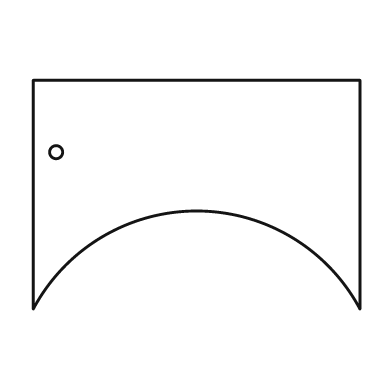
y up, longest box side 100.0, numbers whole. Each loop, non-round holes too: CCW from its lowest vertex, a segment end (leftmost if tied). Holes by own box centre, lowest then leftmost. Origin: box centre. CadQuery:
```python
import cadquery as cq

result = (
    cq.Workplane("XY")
    .moveTo(-50.0, -35.0)
    .threePointArc((0.0, -5.0), (50.0, -35.0))
    .lineTo(50.0, 35.0)
    .lineTo(-50.0, 35.0)
    .close()
    .moveTo(-43.0, 13.0)
    .circle(2.0)
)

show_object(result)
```